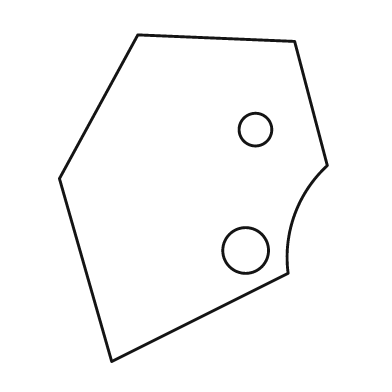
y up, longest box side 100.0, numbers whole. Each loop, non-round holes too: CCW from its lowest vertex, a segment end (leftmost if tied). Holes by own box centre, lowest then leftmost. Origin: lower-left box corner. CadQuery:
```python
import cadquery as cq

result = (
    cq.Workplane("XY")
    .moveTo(16.0, 0.0)
    .lineTo(70.0, 27.0)
    .threePointArc((72.0, 45.0), (82.0, 60.0))
    .lineTo(72.0, 98.0)
    .lineTo(24.0, 100.0)
    .lineTo(0.0, 56.0)
    .close()
    .moveTo(57.0, 34.0)
    .circle(7.0)
    .moveTo(60.0, 71.0)
    .circle(5.0)
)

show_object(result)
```